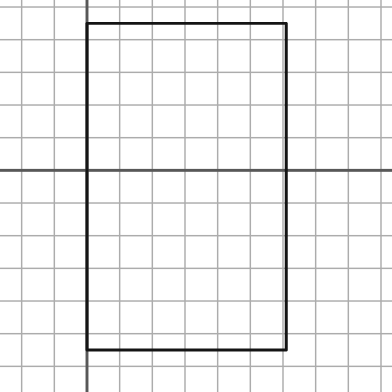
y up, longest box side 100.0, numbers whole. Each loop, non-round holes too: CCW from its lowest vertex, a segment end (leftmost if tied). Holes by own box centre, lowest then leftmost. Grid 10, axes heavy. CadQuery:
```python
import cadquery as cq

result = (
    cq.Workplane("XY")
    .moveTo(0.0, -55.0)
    .lineTo(61.0, -55.0)
    .lineTo(61.0, 45.0)
    .lineTo(0.0, 45.0)
    .close()
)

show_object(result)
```